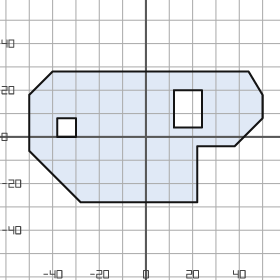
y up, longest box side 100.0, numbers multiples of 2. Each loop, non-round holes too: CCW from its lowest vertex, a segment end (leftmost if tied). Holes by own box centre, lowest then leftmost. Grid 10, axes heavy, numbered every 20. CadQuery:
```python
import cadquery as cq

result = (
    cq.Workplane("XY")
    .moveTo(-28.0, -28.0)
    .lineTo(22.0, -28.0)
    .lineTo(22.0, -4.0)
    .lineTo(38.0, -4.0)
    .lineTo(50.0, 8.0)
    .lineTo(50.0, 18.0)
    .lineTo(44.0, 28.0)
    .lineTo(-40.0, 28.0)
    .lineTo(-50.0, 18.0)
    .lineTo(-50.0, -6.0)
    .close()
    .moveTo(-38.0, 0.0)
    .lineTo(-30.0, 0.0)
    .lineTo(-30.0, 8.0)
    .lineTo(-38.0, 8.0)
    .close()
    .moveTo(12.0, 4.0)
    .lineTo(24.0, 4.0)
    .lineTo(24.0, 20.0)
    .lineTo(12.0, 20.0)
    .close()
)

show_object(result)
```